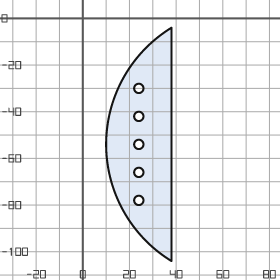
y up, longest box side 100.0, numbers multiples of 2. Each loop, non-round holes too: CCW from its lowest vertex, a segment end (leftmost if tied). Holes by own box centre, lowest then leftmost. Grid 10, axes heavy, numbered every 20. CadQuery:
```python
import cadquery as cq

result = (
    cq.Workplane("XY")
    .moveTo(38.0, -104.0)
    .lineTo(38.0, -4.0)
    .threePointArc((10.0, -54.0), (38.0, -104.0))
    .close()
    .moveTo(24.0, -78.0)
    .circle(2.0)
    .moveTo(24.0, -66.0)
    .circle(2.0)
    .moveTo(24.0, -54.0)
    .circle(2.0)
    .moveTo(24.0, -42.0)
    .circle(2.0)
    .moveTo(24.0, -30.0)
    .circle(2.0)
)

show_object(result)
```